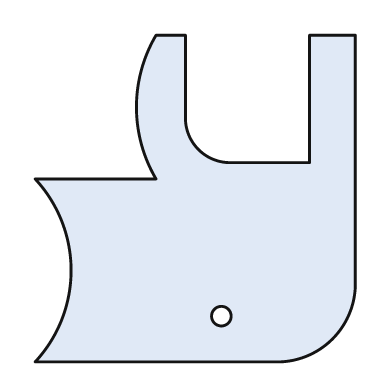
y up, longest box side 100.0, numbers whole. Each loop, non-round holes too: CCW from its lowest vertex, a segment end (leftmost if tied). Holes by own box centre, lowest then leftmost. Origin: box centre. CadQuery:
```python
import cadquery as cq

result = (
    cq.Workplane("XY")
    .moveTo(-49.0, -50.0)
    .lineTo(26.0, -50.0)
    .threePointArc((42.0, -43.0), (49.0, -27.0))
    .lineTo(49.0, 50.0)
    .lineTo(35.0, 50.0)
    .lineTo(35.0, 11.0)
    .lineTo(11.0, 11.0)
    .threePointArc((1.0, 15.0), (-3.0, 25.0))
    .lineTo(-3.0, 50.0)
    .lineTo(-12.0, 50.0)
    .threePointArc((-18.0, 28.0), (-12.0, 6.0))
    .lineTo(-49.0, 6.0)
    .threePointArc((-38.0, -22.0), (-49.0, -50.0))
    .close()
    .moveTo(8.0, -36.0)
    .circle(3.0)
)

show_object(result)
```